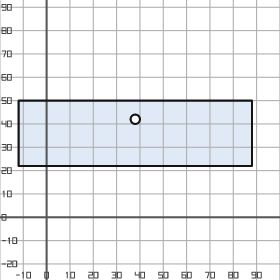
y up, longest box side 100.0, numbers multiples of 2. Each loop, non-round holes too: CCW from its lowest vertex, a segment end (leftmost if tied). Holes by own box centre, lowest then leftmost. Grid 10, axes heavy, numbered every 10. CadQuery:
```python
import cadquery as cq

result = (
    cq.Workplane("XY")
    .moveTo(-12.0, 22.0)
    .lineTo(88.0, 22.0)
    .lineTo(88.0, 50.0)
    .lineTo(-12.0, 50.0)
    .close()
    .moveTo(38.0, 42.0)
    .circle(2.0)
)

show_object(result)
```